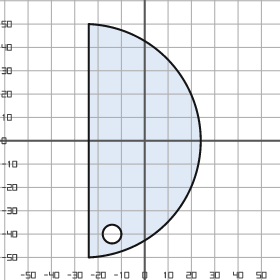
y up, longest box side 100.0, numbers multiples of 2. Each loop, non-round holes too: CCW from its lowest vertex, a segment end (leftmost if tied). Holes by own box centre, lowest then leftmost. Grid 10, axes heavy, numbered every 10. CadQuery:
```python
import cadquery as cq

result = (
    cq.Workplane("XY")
    .moveTo(-24.0, -50.0)
    .threePointArc((24.0, 0.0), (-24.0, 50.0))
    .close()
    .moveTo(-14.0, -40.0)
    .circle(4.0)
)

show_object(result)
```